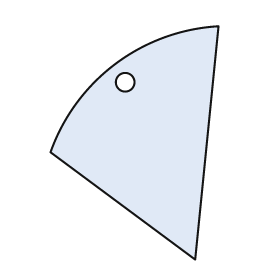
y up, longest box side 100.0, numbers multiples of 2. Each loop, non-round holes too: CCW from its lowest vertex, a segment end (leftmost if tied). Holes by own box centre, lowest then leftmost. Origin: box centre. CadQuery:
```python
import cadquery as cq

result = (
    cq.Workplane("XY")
    .moveTo(26.0, -50.0)
    .lineTo(36.0, 50.0)
    .threePointArc((-8.0, 34.0), (-36.0, -4.0))
    .close()
    .moveTo(-4.0, 26.0)
    .circle(4.0)
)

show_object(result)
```